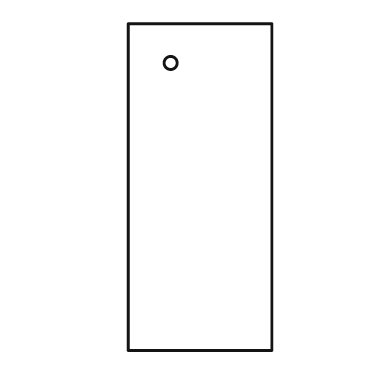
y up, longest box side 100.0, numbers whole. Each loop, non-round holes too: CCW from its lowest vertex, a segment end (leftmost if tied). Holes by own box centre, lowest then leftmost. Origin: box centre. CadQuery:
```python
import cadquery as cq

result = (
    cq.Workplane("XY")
    .moveTo(-22.0, -50.0)
    .lineTo(22.0, -50.0)
    .lineTo(22.0, 50.0)
    .lineTo(-22.0, 50.0)
    .close()
    .moveTo(-9.0, 38.0)
    .circle(2.0)
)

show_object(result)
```